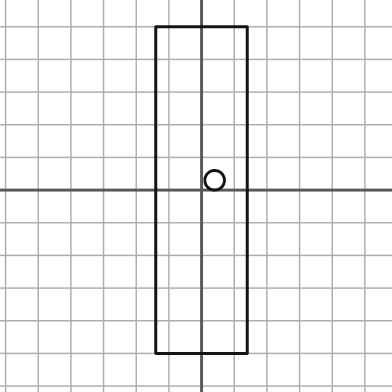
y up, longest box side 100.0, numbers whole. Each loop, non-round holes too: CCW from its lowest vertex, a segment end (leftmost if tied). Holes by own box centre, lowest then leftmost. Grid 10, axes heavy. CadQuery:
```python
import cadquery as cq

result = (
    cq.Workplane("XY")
    .moveTo(-14.0, -50.0)
    .lineTo(14.0, -50.0)
    .lineTo(14.0, 50.0)
    .lineTo(-14.0, 50.0)
    .close()
    .moveTo(4.0, 3.0)
    .circle(3.0)
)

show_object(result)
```